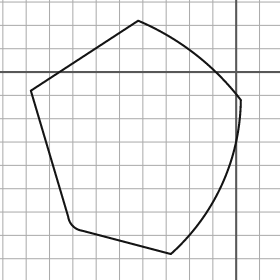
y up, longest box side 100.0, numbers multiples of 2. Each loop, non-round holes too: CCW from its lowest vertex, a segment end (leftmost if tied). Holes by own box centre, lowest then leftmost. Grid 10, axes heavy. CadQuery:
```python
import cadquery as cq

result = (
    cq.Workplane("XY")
    .moveTo(-28.0, -78.0)
    .threePointArc((-6.0, -48.0), (2.0, -12.0))
    .threePointArc((-18.0, 8.0), (-42.0, 22.0))
    .lineTo(-88.0, -8.0)
    .lineTo(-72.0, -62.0)
    .threePointArc((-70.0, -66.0), (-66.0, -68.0))
    .close()
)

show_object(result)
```